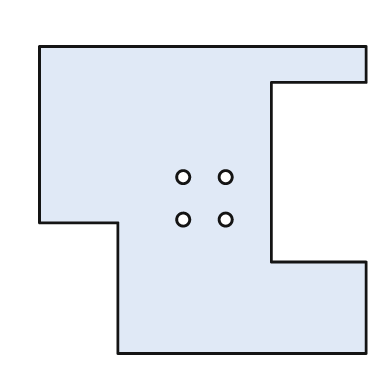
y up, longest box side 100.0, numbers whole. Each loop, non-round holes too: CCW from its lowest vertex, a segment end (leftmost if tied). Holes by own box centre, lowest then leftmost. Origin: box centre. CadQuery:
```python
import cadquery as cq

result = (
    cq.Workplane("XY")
    .moveTo(-26.0, -47.0)
    .lineTo(50.0, -47.0)
    .lineTo(50.0, -19.0)
    .lineTo(21.0, -19.0)
    .lineTo(21.0, 36.0)
    .lineTo(50.0, 36.0)
    .lineTo(50.0, 47.0)
    .lineTo(-50.0, 47.0)
    .lineTo(-50.0, -7.0)
    .lineTo(-26.0, -7.0)
    .close()
    .moveTo(-6.0, -6.0)
    .circle(2.0)
    .moveTo(7.0, -6.0)
    .circle(2.0)
    .moveTo(-6.0, 7.0)
    .circle(2.0)
    .moveTo(7.0, 7.0)
    .circle(2.0)
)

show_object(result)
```